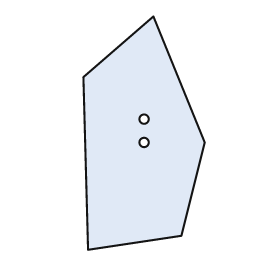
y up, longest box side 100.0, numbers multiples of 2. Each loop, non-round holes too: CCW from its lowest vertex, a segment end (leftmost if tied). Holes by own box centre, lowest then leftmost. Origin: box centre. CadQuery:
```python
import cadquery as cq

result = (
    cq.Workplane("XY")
    .moveTo(-24.0, -50.0)
    .lineTo(16.0, -44.0)
    .lineTo(26.0, -4.0)
    .lineTo(4.0, 50.0)
    .lineTo(-26.0, 24.0)
    .close()
    .moveTo(0.0, -4.0)
    .circle(2.0)
    .moveTo(0.0, 6.0)
    .circle(2.0)
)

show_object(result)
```